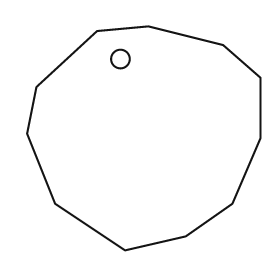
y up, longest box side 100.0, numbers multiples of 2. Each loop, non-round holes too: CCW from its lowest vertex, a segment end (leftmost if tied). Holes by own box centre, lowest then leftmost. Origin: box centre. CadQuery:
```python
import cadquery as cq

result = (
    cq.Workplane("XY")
    .moveTo(-8.0, -48.0)
    .lineTo(18.0, -42.0)
    .lineTo(38.0, -28.0)
    .lineTo(50.0, 0.0)
    .lineTo(50.0, 26.0)
    .lineTo(34.0, 40.0)
    .lineTo(2.0, 48.0)
    .lineTo(-20.0, 46.0)
    .lineTo(-46.0, 22.0)
    .lineTo(-50.0, 2.0)
    .lineTo(-38.0, -28.0)
    .close()
    .moveTo(-10.0, 34.0)
    .circle(4.0)
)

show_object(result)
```